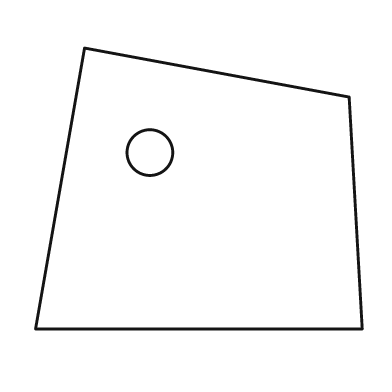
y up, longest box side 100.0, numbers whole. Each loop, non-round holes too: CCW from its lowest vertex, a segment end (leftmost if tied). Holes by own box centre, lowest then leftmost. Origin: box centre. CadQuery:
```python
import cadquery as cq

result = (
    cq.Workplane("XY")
    .moveTo(-50.0, -43.0)
    .lineTo(50.0, -43.0)
    .lineTo(46.0, 28.0)
    .lineTo(-35.0, 43.0)
    .close()
    .moveTo(-15.0, 11.0)
    .circle(7.0)
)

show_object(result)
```